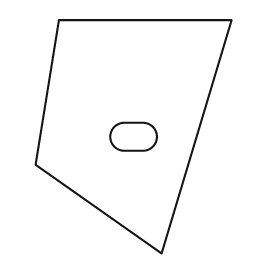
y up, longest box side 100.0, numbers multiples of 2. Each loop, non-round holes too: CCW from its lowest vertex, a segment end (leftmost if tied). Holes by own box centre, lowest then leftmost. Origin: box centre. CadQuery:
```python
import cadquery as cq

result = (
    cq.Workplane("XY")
    .moveTo(12.0, -50.0)
    .lineTo(42.0, 50.0)
    .lineTo(-32.0, 50.0)
    .lineTo(-42.0, -12.0)
    .close()
    .moveTo(-4.0, -6.0)
    .lineTo(4.0, -6.0)
    .threePointArc((10.0, 0.0), (4.0, 6.0))
    .lineTo(-4.0, 6.0)
    .threePointArc((-10.0, 0.0), (-4.0, -6.0))
    .close()
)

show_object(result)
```